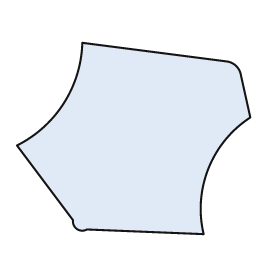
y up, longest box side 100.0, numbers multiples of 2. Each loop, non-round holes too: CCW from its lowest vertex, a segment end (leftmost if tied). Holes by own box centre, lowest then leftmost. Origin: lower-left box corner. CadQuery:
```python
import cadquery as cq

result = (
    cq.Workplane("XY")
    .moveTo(80.0, 0.0)
    .threePointArc((82.0, 28.0), (100.0, 50.0))
    .lineTo(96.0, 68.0)
    .threePointArc((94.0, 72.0), (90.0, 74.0))
    .lineTo(28.0, 82.0)
    .threePointArc((20.0, 56.0), (0.0, 38.0))
    .lineTo(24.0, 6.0)
    .threePointArc((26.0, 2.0), (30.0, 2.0))
    .close()
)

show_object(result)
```